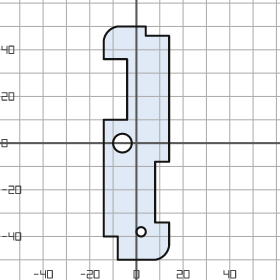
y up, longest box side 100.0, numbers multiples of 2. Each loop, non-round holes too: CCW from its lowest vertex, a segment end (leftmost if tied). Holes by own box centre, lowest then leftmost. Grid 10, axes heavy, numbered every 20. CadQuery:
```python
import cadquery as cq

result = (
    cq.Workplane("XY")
    .moveTo(-8.0, -50.0)
    .lineTo(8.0, -50.0)
    .threePointArc((12.0, -48.0), (14.0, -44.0))
    .lineTo(14.0, -34.0)
    .lineTo(8.0, -34.0)
    .lineTo(8.0, -8.0)
    .lineTo(14.0, -8.0)
    .lineTo(14.0, 46.0)
    .lineTo(4.0, 46.0)
    .lineTo(4.0, 50.0)
    .lineTo(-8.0, 50.0)
    .threePointArc((-12.0, 48.0), (-14.0, 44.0))
    .lineTo(-14.0, 36.0)
    .lineTo(-4.0, 36.0)
    .lineTo(-4.0, 10.0)
    .lineTo(-14.0, 10.0)
    .lineTo(-14.0, -40.0)
    .lineTo(-8.0, -40.0)
    .close()
    .moveTo(2.0, -38.0)
    .circle(2.0)
    .moveTo(-6.0, 0.0)
    .circle(4.0)
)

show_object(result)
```